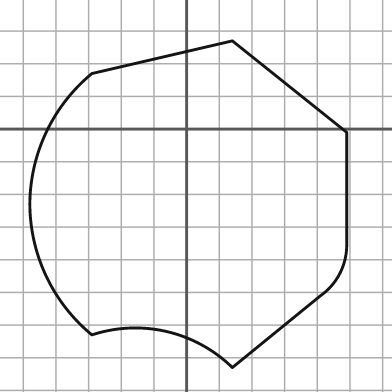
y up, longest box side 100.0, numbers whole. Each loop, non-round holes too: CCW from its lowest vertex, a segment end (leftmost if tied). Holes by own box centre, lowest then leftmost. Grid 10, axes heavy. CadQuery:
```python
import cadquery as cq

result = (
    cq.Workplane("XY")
    .moveTo(14.0, -73.0)
    .lineTo(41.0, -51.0)
    .threePointArc((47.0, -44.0), (49.0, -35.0))
    .lineTo(49.0, -1.0)
    .lineTo(14.0, 27.0)
    .lineTo(-29.0, 17.0)
    .threePointArc((-43.0, -1.0), (-48.0, -23.0))
    .threePointArc((-43.0, -45.0), (-29.0, -63.0))
    .threePointArc((-6.0, -62.0), (14.0, -73.0))
    .close()
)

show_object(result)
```